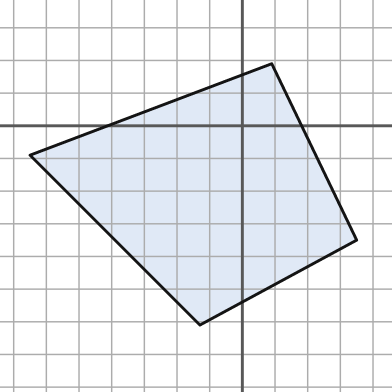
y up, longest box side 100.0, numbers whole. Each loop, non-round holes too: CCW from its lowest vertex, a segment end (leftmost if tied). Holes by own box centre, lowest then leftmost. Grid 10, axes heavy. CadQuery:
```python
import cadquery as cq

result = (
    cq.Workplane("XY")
    .moveTo(-13.0, -61.0)
    .lineTo(35.0, -35.0)
    .lineTo(9.0, 19.0)
    .lineTo(-65.0, -9.0)
    .close()
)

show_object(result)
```